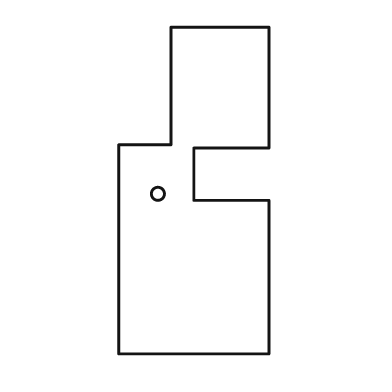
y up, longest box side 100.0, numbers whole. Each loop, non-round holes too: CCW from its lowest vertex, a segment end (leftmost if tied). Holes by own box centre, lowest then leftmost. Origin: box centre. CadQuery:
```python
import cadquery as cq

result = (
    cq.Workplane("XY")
    .moveTo(-23.0, -50.0)
    .lineTo(23.0, -50.0)
    .lineTo(23.0, -3.0)
    .lineTo(0.0, -3.0)
    .lineTo(0.0, 13.0)
    .lineTo(23.0, 13.0)
    .lineTo(23.0, 50.0)
    .lineTo(-7.0, 50.0)
    .lineTo(-7.0, 14.0)
    .lineTo(-23.0, 14.0)
    .close()
    .moveTo(-11.0, -1.0)
    .circle(2.0)
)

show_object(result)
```